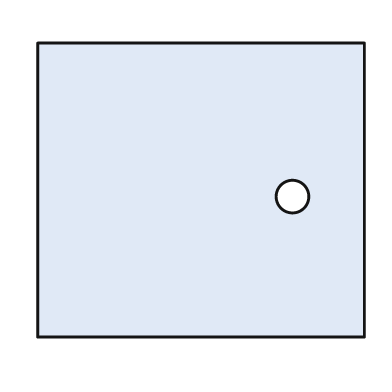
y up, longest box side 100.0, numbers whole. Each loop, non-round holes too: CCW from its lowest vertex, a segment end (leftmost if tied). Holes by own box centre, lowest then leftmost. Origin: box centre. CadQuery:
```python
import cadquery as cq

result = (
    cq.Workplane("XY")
    .moveTo(-50.0, -45.0)
    .lineTo(50.0, -45.0)
    .lineTo(50.0, 45.0)
    .lineTo(-50.0, 45.0)
    .close()
    .moveTo(28.0, -2.0)
    .circle(5.0)
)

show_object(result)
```